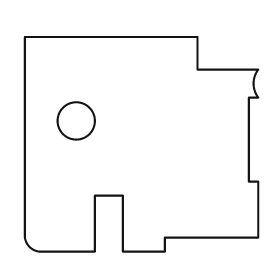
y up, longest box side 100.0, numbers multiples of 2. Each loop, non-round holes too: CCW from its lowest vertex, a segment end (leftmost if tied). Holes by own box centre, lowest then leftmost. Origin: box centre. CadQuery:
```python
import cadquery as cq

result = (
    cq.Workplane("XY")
    .moveTo(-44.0, -46.0)
    .lineTo(-20.0, -46.0)
    .lineTo(-20.0, -22.0)
    .lineTo(-8.0, -22.0)
    .lineTo(-8.0, -46.0)
    .lineTo(10.0, -46.0)
    .lineTo(10.0, -40.0)
    .lineTo(50.0, -40.0)
    .lineTo(50.0, -16.0)
    .lineTo(46.0, -16.0)
    .lineTo(46.0, 20.0)
    .lineTo(50.0, 20.0)
    .threePointArc((48.0, 26.0), (50.0, 32.0))
    .lineTo(24.0, 32.0)
    .lineTo(24.0, 46.0)
    .lineTo(-50.0, 46.0)
    .lineTo(-50.0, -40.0)
    .threePointArc((-48.0, -44.0), (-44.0, -46.0))
    .close()
    .moveTo(-28.0, 10.0)
    .circle(8.0)
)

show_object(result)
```